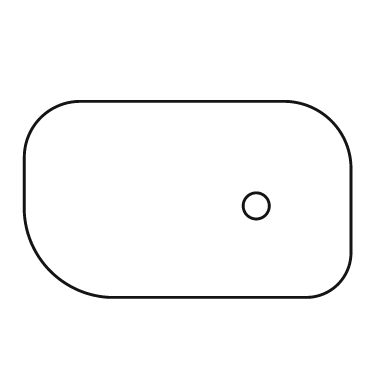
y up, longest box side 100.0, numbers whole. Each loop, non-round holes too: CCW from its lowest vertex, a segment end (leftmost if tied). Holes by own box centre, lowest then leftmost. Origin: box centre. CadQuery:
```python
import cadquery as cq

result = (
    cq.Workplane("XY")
    .moveTo(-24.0, -30.0)
    .lineTo(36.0, -30.0)
    .threePointArc((46.0, -26.0), (50.0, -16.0))
    .lineTo(50.0, 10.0)
    .threePointArc((44.0, 24.0), (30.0, 30.0))
    .lineTo(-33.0, 30.0)
    .threePointArc((-45.0, 25.0), (-50.0, 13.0))
    .lineTo(-50.0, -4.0)
    .threePointArc((-42.0, -22.0), (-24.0, -30.0))
    .close()
    .moveTo(21.0, -2.0)
    .circle(4.0)
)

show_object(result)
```